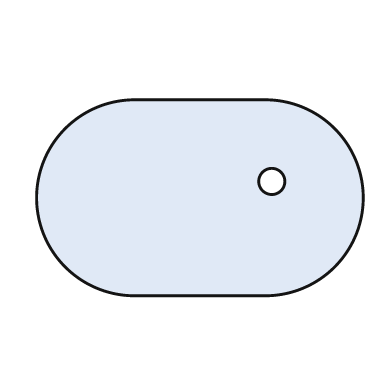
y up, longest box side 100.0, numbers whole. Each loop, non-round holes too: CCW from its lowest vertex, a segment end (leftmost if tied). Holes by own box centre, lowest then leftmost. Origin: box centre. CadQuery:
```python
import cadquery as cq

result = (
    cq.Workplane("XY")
    .moveTo(-20.0, -30.0)
    .lineTo(20.0, -30.0)
    .threePointArc((50.0, 0.0), (20.0, 30.0))
    .lineTo(-20.0, 30.0)
    .threePointArc((-50.0, 0.0), (-20.0, -30.0))
    .close()
    .moveTo(22.0, 5.0)
    .circle(4.0)
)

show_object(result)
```